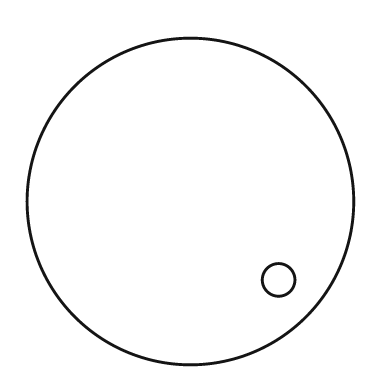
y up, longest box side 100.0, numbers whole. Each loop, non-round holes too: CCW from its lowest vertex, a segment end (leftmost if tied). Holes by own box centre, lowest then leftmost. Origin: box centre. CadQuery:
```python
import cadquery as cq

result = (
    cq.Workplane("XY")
    .moveTo(0.0, 0.0)
    .circle(50.0)
    .moveTo(27.0, -24.0)
    .circle(5.0)
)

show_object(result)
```